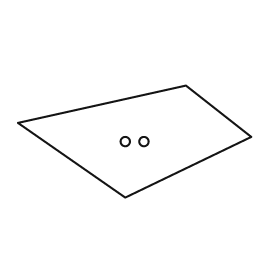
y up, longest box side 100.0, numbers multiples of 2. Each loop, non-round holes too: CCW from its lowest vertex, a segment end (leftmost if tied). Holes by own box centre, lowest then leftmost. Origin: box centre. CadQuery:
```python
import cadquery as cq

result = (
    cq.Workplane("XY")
    .moveTo(-4.0, -24.0)
    .lineTo(50.0, 2.0)
    .lineTo(22.0, 24.0)
    .lineTo(-50.0, 8.0)
    .close()
    .moveTo(-4.0, 0.0)
    .circle(2.0)
    .moveTo(4.0, 0.0)
    .circle(2.0)
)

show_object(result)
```